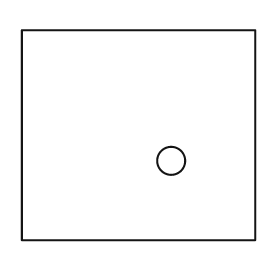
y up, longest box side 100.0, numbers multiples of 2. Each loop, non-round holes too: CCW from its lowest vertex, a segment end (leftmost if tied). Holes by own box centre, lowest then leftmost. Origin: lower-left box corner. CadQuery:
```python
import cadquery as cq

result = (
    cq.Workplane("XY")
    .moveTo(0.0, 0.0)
    .lineTo(100.0, 0.0)
    .lineTo(100.0, 90.0)
    .lineTo(0.0, 90.0)
    .close()
    .moveTo(64.0, 34.0)
    .circle(6.0)
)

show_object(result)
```